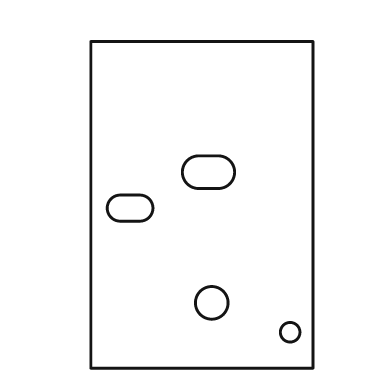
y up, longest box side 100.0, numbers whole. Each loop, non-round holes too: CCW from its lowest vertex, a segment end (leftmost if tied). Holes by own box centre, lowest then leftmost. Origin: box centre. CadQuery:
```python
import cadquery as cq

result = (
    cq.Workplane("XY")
    .moveTo(-34.0, -50.0)
    .lineTo(34.0, -50.0)
    .lineTo(34.0, 50.0)
    .lineTo(-34.0, 50.0)
    .close()
    .moveTo(27.0, -39.0)
    .circle(3.0)
    .moveTo(3.0, -30.0)
    .circle(5.0)
    .moveTo(-25.0, -5.0)
    .lineTo(-19.0, -5.0)
    .threePointArc((-15.0, -1.0), (-19.0, 3.0))
    .lineTo(-25.0, 3.0)
    .threePointArc((-29.0, -1.0), (-25.0, -5.0))
    .close()
    .moveTo(-1.0, 5.0)
    .lineTo(5.0, 5.0)
    .threePointArc((10.0, 10.0), (5.0, 15.0))
    .lineTo(-1.0, 15.0)
    .threePointArc((-6.0, 10.0), (-1.0, 5.0))
    .close()
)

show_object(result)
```